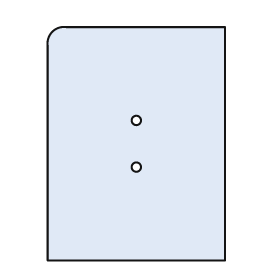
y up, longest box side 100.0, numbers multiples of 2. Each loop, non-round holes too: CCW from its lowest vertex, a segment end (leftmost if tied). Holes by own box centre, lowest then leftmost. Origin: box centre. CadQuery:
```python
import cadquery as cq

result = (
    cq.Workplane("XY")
    .moveTo(-38.0, -50.0)
    .lineTo(38.0, -50.0)
    .lineTo(38.0, 50.0)
    .lineTo(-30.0, 50.0)
    .threePointArc((-36.0, 48.0), (-38.0, 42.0))
    .close()
    .moveTo(0.0, -10.0)
    .circle(2.0)
    .moveTo(0.0, 10.0)
    .circle(2.0)
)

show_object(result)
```